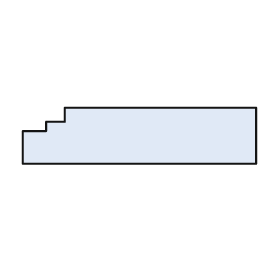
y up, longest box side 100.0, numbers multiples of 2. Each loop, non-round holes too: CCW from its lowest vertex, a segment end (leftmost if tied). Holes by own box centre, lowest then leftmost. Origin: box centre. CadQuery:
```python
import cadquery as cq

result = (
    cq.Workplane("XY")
    .moveTo(-50.0, -12.0)
    .lineTo(50.0, -12.0)
    .lineTo(50.0, 12.0)
    .lineTo(-32.0, 12.0)
    .lineTo(-32.0, 6.0)
    .lineTo(-40.0, 6.0)
    .lineTo(-40.0, 2.0)
    .lineTo(-50.0, 2.0)
    .close()
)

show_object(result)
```